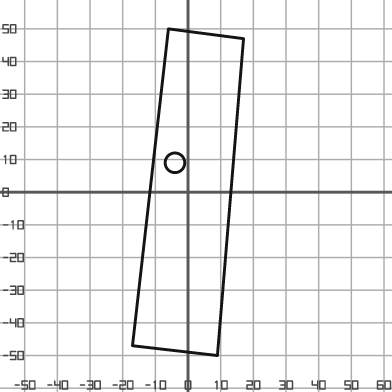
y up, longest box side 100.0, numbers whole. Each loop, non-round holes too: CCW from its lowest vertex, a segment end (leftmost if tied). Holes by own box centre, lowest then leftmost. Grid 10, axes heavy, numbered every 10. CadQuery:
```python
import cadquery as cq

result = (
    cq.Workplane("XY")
    .moveTo(9.0, -50.0)
    .lineTo(17.0, 47.0)
    .lineTo(-6.0, 50.0)
    .lineTo(-17.0, -47.0)
    .close()
    .moveTo(-4.0, 9.0)
    .circle(3.0)
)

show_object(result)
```